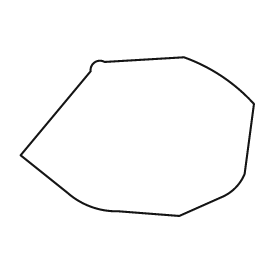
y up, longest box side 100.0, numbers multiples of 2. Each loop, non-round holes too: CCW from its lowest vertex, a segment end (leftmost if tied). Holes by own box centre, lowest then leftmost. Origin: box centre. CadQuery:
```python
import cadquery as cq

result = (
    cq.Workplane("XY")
    .moveTo(18.0, -34.0)
    .lineTo(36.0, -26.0)
    .threePointArc((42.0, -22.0), (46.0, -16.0))
    .lineTo(50.0, 14.0)
    .threePointArc((36.0, 26.0), (20.0, 34.0))
    .lineTo(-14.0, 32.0)
    .threePointArc((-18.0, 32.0), (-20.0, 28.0))
    .lineTo(-50.0, -8.0)
    .lineTo(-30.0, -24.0)
    .threePointArc((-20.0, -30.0), (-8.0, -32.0))
    .close()
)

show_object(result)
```